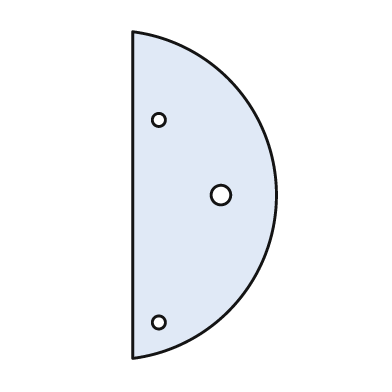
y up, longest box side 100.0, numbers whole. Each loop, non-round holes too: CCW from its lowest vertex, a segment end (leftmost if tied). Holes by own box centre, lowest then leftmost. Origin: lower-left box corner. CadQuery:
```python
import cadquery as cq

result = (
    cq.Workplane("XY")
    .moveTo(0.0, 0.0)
    .threePointArc((44.0, 50.0), (0.0, 100.0))
    .close()
    .moveTo(8.0, 11.0)
    .circle(2.0)
    .moveTo(27.0, 50.0)
    .circle(3.0)
    .moveTo(8.0, 73.0)
    .circle(2.0)
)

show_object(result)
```